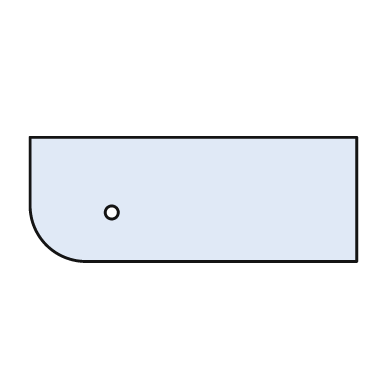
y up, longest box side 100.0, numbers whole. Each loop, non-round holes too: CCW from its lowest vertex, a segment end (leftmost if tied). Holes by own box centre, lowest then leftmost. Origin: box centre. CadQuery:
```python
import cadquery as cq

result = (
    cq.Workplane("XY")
    .moveTo(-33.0, -19.0)
    .lineTo(50.0, -19.0)
    .lineTo(50.0, 19.0)
    .lineTo(-50.0, 19.0)
    .lineTo(-50.0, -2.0)
    .threePointArc((-45.0, -14.0), (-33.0, -19.0))
    .close()
    .moveTo(-25.0, -4.0)
    .circle(2.0)
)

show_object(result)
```